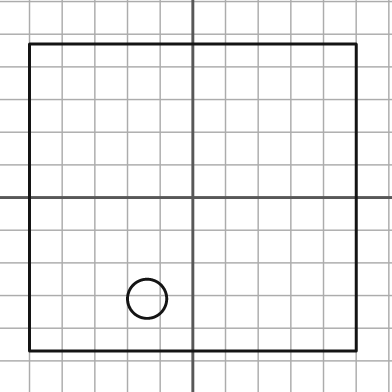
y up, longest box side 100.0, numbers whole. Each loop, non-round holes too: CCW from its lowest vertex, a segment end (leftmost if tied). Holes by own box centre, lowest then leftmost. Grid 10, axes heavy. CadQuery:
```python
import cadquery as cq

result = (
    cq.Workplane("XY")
    .moveTo(-50.0, -47.0)
    .lineTo(50.0, -47.0)
    .lineTo(50.0, 47.0)
    .lineTo(-50.0, 47.0)
    .close()
    .moveTo(-14.0, -31.0)
    .circle(6.0)
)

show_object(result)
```